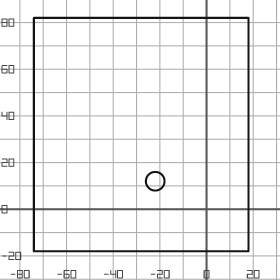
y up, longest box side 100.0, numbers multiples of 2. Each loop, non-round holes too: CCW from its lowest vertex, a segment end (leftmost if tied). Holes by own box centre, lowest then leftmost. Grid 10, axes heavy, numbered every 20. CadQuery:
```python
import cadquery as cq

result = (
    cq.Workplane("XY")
    .moveTo(-74.0, -18.0)
    .lineTo(18.0, -18.0)
    .lineTo(18.0, 82.0)
    .lineTo(-74.0, 82.0)
    .close()
    .moveTo(-22.0, 12.0)
    .circle(4.0)
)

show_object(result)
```